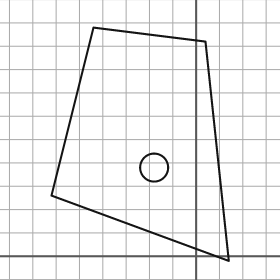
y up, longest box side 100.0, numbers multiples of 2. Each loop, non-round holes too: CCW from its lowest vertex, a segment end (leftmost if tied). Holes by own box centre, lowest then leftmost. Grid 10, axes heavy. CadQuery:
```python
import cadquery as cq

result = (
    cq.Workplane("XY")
    .moveTo(14.0, -2.0)
    .lineTo(4.0, 92.0)
    .lineTo(-44.0, 98.0)
    .lineTo(-62.0, 26.0)
    .close()
    .moveTo(-18.0, 38.0)
    .circle(6.0)
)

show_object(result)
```